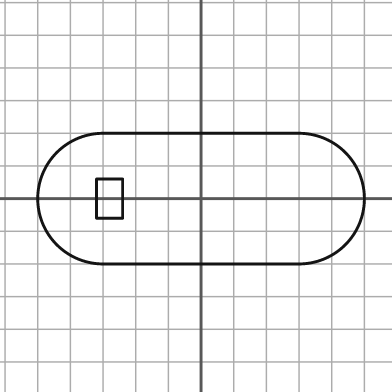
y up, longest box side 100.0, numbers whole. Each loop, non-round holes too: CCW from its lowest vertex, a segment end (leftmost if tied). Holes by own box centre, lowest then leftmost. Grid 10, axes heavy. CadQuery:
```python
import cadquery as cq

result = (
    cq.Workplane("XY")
    .moveTo(-30.0, -20.0)
    .lineTo(30.0, -20.0)
    .threePointArc((50.0, 0.0), (30.0, 20.0))
    .lineTo(-30.0, 20.0)
    .threePointArc((-50.0, 0.0), (-30.0, -20.0))
    .close()
    .moveTo(-32.0, -6.0)
    .lineTo(-24.0, -6.0)
    .lineTo(-24.0, 6.0)
    .lineTo(-32.0, 6.0)
    .close()
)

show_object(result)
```